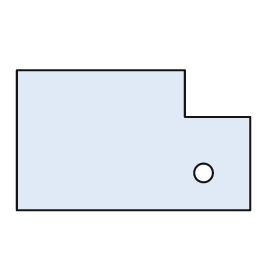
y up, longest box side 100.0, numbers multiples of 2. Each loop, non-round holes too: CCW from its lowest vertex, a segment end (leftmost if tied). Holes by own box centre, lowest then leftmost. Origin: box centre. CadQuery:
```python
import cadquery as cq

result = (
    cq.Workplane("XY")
    .moveTo(-50.0, -30.0)
    .lineTo(50.0, -30.0)
    .lineTo(50.0, 10.0)
    .lineTo(22.0, 10.0)
    .lineTo(22.0, 30.0)
    .lineTo(-50.0, 30.0)
    .close()
    .moveTo(30.0, -14.0)
    .circle(4.0)
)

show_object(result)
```